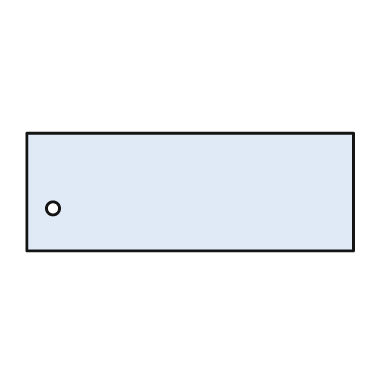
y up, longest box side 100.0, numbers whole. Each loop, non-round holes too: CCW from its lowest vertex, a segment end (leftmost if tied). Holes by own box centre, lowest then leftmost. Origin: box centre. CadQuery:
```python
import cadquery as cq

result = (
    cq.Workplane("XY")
    .moveTo(-50.0, -18.0)
    .lineTo(50.0, -18.0)
    .lineTo(50.0, 18.0)
    .lineTo(-50.0, 18.0)
    .close()
    .moveTo(-42.0, -5.0)
    .circle(2.0)
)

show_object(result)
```